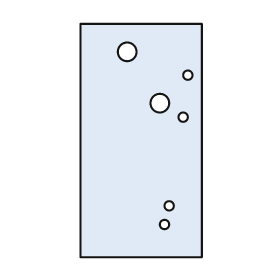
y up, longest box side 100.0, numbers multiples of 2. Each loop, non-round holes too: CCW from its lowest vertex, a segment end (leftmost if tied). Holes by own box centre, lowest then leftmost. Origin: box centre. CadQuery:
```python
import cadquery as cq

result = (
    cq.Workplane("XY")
    .moveTo(-26.0, -50.0)
    .lineTo(26.0, -50.0)
    .lineTo(26.0, 50.0)
    .lineTo(-26.0, 50.0)
    .close()
    .moveTo(10.0, -36.0)
    .circle(2.0)
    .moveTo(12.0, -28.0)
    .circle(2.0)
    .moveTo(18.0, 10.0)
    .circle(2.0)
    .moveTo(8.0, 16.0)
    .circle(4.0)
    .moveTo(20.0, 28.0)
    .circle(2.0)
    .moveTo(-6.0, 38.0)
    .circle(4.0)
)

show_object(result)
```